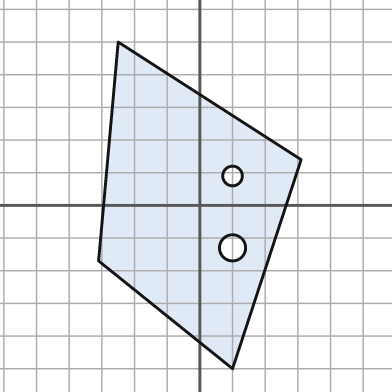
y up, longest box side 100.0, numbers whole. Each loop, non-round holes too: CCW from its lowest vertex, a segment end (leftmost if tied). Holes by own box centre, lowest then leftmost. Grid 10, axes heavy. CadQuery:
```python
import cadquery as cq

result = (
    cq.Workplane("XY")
    .moveTo(10.0, -50.0)
    .lineTo(31.0, 14.0)
    .lineTo(-25.0, 50.0)
    .lineTo(-31.0, -17.0)
    .close()
    .moveTo(10.0, -13.0)
    .circle(4.0)
    .moveTo(10.0, 9.0)
    .circle(3.0)
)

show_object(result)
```